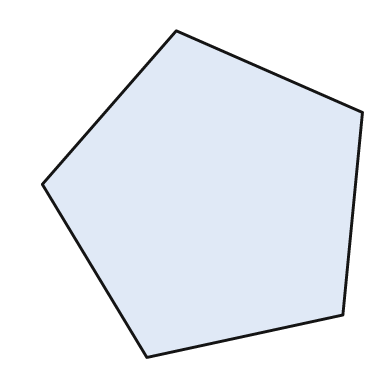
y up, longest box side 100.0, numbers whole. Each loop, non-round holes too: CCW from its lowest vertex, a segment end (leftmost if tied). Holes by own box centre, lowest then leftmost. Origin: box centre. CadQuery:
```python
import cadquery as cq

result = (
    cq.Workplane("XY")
    .moveTo(-17.0, -50.0)
    .lineTo(43.0, -37.0)
    .lineTo(49.0, 25.0)
    .lineTo(-8.0, 50.0)
    .lineTo(-49.0, 3.0)
    .close()
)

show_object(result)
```